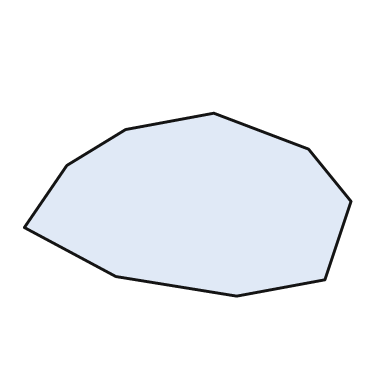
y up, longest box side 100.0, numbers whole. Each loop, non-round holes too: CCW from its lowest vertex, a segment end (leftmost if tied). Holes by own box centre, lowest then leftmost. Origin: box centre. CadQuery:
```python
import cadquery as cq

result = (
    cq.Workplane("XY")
    .moveTo(15.0, -28.0)
    .lineTo(42.0, -23.0)
    .lineTo(50.0, 1.0)
    .lineTo(37.0, 17.0)
    .lineTo(8.0, 28.0)
    .lineTo(-19.0, 23.0)
    .lineTo(-37.0, 12.0)
    .lineTo(-50.0, -7.0)
    .lineTo(-22.0, -22.0)
    .close()
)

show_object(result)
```